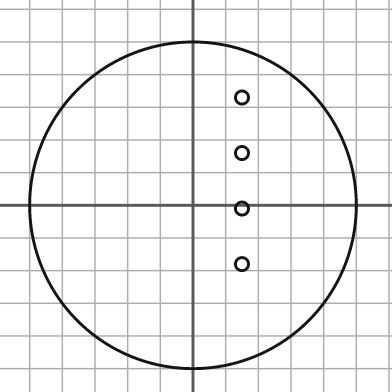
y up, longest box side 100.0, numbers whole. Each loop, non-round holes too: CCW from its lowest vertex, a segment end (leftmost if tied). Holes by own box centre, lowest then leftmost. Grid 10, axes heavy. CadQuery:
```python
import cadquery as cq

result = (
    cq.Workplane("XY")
    .moveTo(0.0, 0.0)
    .circle(50.0)
    .moveTo(15.0, -18.0)
    .circle(2.0)
    .moveTo(15.0, -1.0)
    .circle(2.0)
    .moveTo(15.0, 16.0)
    .circle(2.0)
    .moveTo(15.0, 33.0)
    .circle(2.0)
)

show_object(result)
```